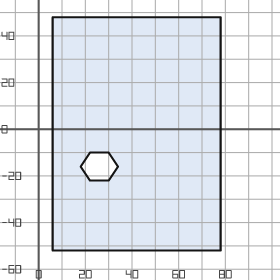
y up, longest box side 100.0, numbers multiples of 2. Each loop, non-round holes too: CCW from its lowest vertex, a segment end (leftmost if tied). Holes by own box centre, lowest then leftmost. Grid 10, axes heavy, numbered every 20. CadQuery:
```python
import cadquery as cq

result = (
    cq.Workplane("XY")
    .moveTo(6.0, -52.0)
    .lineTo(78.0, -52.0)
    .lineTo(78.0, 48.0)
    .lineTo(6.0, 48.0)
    .close()
    .moveTo(22.0, -22.0)
    .lineTo(30.0, -22.0)
    .lineTo(34.0, -16.0)
    .lineTo(30.0, -10.0)
    .lineTo(22.0, -10.0)
    .lineTo(18.0, -16.0)
    .close()
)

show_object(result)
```